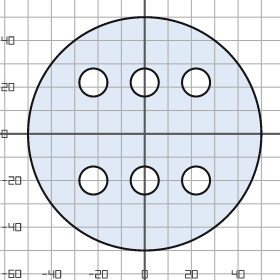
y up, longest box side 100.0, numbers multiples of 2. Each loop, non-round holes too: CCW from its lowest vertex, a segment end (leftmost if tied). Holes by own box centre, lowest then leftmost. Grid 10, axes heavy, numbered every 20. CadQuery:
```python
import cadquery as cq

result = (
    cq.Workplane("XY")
    .moveTo(0.0, 0.0)
    .circle(50.0)
    .moveTo(-22.0, -20.0)
    .circle(6.0)
    .moveTo(0.0, -20.0)
    .circle(6.0)
    .moveTo(22.0, -20.0)
    .circle(6.0)
    .moveTo(-22.0, 22.0)
    .circle(6.0)
    .moveTo(0.0, 22.0)
    .circle(6.0)
    .moveTo(22.0, 22.0)
    .circle(6.0)
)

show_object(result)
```